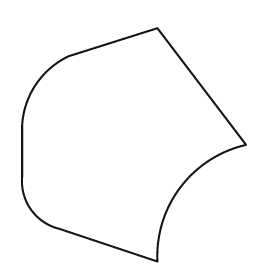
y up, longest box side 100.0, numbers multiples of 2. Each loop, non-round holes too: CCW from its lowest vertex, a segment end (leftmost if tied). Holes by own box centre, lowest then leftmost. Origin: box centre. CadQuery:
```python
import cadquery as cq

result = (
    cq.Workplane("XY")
    .moveTo(10.0, -50.0)
    .threePointArc((20.0, -18.0), (48.0, 0.0))
    .lineTo(10.0, 50.0)
    .lineTo(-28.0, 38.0)
    .threePointArc((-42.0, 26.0), (-48.0, 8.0))
    .lineTo(-48.0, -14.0)
    .threePointArc((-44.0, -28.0), (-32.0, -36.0))
    .close()
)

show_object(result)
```